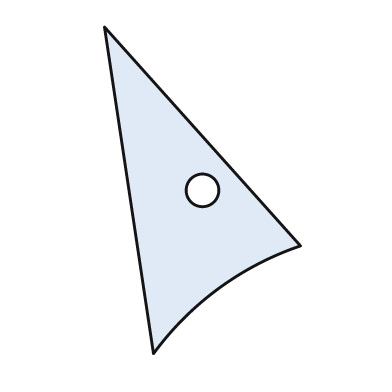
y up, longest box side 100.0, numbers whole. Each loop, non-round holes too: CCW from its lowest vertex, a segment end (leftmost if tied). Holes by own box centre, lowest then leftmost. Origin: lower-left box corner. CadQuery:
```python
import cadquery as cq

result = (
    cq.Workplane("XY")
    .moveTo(15.0, 0.0)
    .threePointArc((35.0, 20.0), (60.0, 33.0))
    .lineTo(0.0, 100.0)
    .close()
    .moveTo(30.0, 50.0)
    .circle(5.0)
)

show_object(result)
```